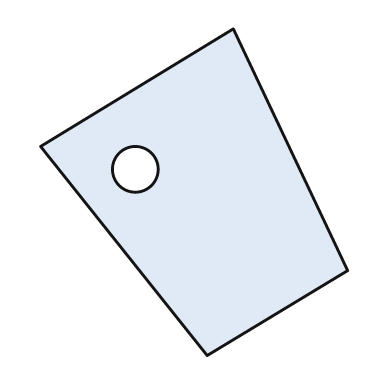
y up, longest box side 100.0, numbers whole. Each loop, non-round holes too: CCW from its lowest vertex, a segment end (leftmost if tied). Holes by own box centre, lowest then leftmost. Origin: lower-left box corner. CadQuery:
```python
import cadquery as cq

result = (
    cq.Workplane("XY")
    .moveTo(51.0, 0.0)
    .lineTo(94.0, 26.0)
    .lineTo(59.0, 100.0)
    .lineTo(0.0, 64.0)
    .close()
    .moveTo(29.0, 57.0)
    .circle(7.0)
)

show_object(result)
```